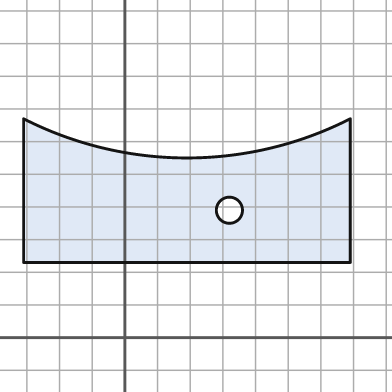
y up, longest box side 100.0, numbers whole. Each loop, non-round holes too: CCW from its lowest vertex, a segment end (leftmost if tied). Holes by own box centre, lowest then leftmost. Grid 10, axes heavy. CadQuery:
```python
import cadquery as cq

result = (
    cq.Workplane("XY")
    .moveTo(-31.0, 23.0)
    .lineTo(69.0, 23.0)
    .lineTo(69.0, 67.0)
    .threePointArc((19.0, 55.0), (-31.0, 67.0))
    .close()
    .moveTo(32.0, 39.0)
    .circle(4.0)
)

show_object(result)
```